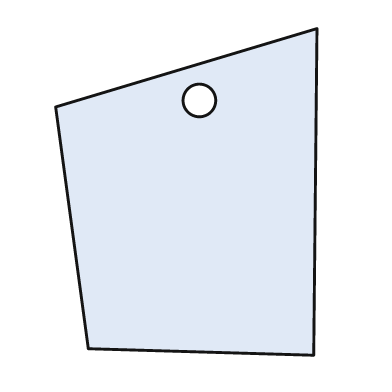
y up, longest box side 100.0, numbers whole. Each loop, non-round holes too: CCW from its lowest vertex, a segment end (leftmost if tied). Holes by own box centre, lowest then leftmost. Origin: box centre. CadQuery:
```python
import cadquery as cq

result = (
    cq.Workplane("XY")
    .moveTo(39.0, -50.0)
    .lineTo(40.0, 50.0)
    .lineTo(-40.0, 26.0)
    .lineTo(-30.0, -48.0)
    .close()
    .moveTo(4.0, 28.0)
    .circle(5.0)
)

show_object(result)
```